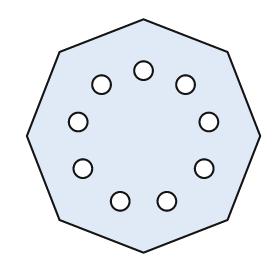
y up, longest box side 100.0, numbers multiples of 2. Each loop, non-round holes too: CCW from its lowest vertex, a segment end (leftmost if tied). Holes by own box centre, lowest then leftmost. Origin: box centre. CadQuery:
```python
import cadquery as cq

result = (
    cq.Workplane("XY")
    .moveTo(0.0, -50.0)
    .lineTo(36.0, -36.0)
    .lineTo(50.0, 0.0)
    .lineTo(36.0, 36.0)
    .lineTo(0.0, 50.0)
    .lineTo(-36.0, 36.0)
    .lineTo(-50.0, 0.0)
    .lineTo(-36.0, -36.0)
    .close()
    .moveTo(-10.0, -28.0)
    .circle(4.0)
    .moveTo(10.0, -28.0)
    .circle(4.0)
    .moveTo(-26.0, -14.0)
    .circle(4.0)
    .moveTo(26.0, -14.0)
    .circle(4.0)
    .moveTo(-28.0, 6.0)
    .circle(4.0)
    .moveTo(28.0, 6.0)
    .circle(4.0)
    .moveTo(-18.0, 22.0)
    .circle(4.0)
    .moveTo(18.0, 22.0)
    .circle(4.0)
    .moveTo(0.0, 28.0)
    .circle(4.0)
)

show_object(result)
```